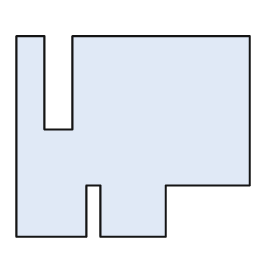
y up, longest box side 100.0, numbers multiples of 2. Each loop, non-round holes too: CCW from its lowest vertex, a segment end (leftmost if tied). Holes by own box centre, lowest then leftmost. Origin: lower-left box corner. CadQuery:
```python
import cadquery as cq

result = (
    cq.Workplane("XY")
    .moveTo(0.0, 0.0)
    .lineTo(30.0, 0.0)
    .lineTo(30.0, 22.0)
    .lineTo(36.0, 22.0)
    .lineTo(36.0, 0.0)
    .lineTo(64.0, 0.0)
    .lineTo(64.0, 22.0)
    .lineTo(100.0, 22.0)
    .lineTo(100.0, 86.0)
    .lineTo(24.0, 86.0)
    .lineTo(24.0, 46.0)
    .lineTo(12.0, 46.0)
    .lineTo(12.0, 86.0)
    .lineTo(0.0, 86.0)
    .close()
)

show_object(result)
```